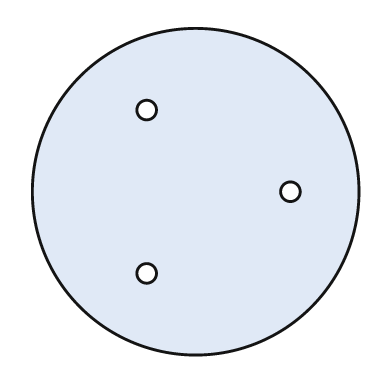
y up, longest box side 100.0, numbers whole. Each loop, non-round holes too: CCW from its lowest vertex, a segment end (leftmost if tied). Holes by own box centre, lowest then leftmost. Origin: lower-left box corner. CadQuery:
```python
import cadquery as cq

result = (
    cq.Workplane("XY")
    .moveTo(50.0, 50.0)
    .circle(50.0)
    .moveTo(35.0, 25.0)
    .circle(3.0)
    .moveTo(79.0, 50.0)
    .circle(3.0)
    .moveTo(35.0, 75.0)
    .circle(3.0)
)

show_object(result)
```